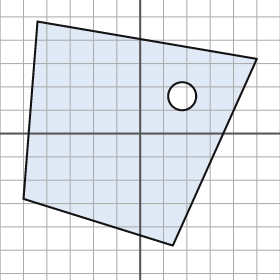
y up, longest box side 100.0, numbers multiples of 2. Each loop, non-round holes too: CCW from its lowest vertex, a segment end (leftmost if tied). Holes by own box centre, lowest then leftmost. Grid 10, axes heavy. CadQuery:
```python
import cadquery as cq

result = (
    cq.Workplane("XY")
    .moveTo(14.0, -48.0)
    .lineTo(50.0, 32.0)
    .lineTo(-44.0, 48.0)
    .lineTo(-50.0, -28.0)
    .close()
    .moveTo(18.0, 16.0)
    .circle(6.0)
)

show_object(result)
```